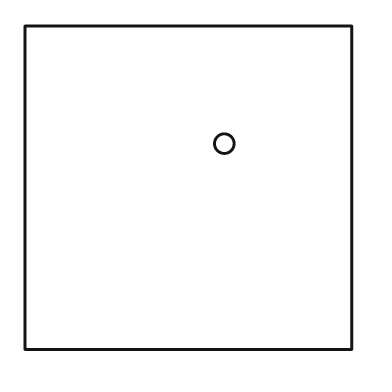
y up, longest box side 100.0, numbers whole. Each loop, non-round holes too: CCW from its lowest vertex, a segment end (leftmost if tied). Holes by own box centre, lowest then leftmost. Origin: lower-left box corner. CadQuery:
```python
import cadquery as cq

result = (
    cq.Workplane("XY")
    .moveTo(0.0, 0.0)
    .lineTo(100.0, 0.0)
    .lineTo(100.0, 99.0)
    .lineTo(0.0, 99.0)
    .close()
    .moveTo(61.0, 63.0)
    .circle(3.0)
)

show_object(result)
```